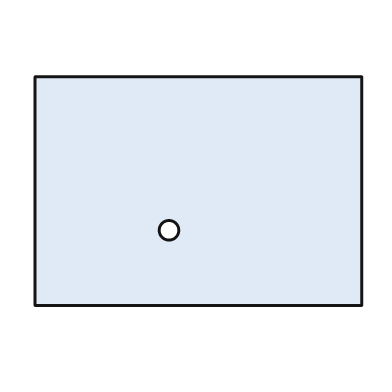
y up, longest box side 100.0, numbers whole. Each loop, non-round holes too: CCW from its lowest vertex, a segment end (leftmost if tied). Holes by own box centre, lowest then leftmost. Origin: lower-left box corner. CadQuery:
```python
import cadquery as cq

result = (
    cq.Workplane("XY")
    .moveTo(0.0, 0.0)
    .lineTo(100.0, 0.0)
    .lineTo(100.0, 70.0)
    .lineTo(0.0, 70.0)
    .close()
    .moveTo(41.0, 23.0)
    .circle(3.0)
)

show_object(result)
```